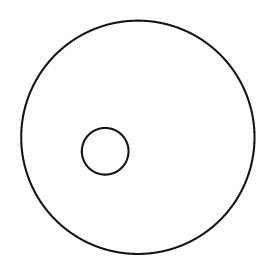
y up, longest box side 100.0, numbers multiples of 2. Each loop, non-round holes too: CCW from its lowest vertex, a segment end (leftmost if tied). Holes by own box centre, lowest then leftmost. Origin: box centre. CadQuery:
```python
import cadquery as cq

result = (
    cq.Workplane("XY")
    .moveTo(0.0, 0.0)
    .circle(50.0)
    .moveTo(-14.0, -6.0)
    .circle(10.0)
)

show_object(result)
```